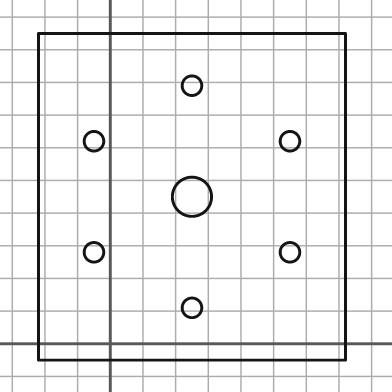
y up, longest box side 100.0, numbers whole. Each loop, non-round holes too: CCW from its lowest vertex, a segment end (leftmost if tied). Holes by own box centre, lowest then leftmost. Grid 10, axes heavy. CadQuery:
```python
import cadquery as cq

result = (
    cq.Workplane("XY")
    .moveTo(-22.0, -5.0)
    .lineTo(72.0, -5.0)
    .lineTo(72.0, 95.0)
    .lineTo(-22.0, 95.0)
    .close()
    .moveTo(25.0, 11.0)
    .circle(3.0)
    .moveTo(-5.0, 28.0)
    .circle(3.0)
    .moveTo(55.0, 28.0)
    .circle(3.0)
    .moveTo(25.0, 45.0)
    .circle(6.0)
    .moveTo(-5.0, 62.0)
    .circle(3.0)
    .moveTo(55.0, 62.0)
    .circle(3.0)
    .moveTo(25.0, 79.0)
    .circle(3.0)
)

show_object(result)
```